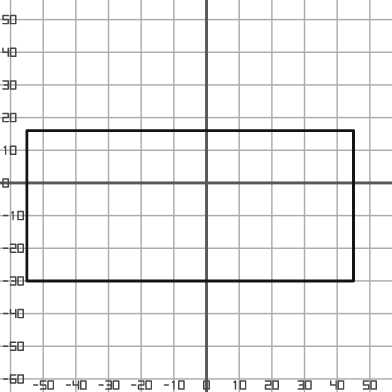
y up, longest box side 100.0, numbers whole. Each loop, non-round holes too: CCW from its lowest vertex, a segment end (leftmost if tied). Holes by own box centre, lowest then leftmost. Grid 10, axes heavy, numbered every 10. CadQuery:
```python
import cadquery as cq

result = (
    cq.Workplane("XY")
    .moveTo(-55.0, -30.0)
    .lineTo(45.0, -30.0)
    .lineTo(45.0, 16.0)
    .lineTo(-55.0, 16.0)
    .close()
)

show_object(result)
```